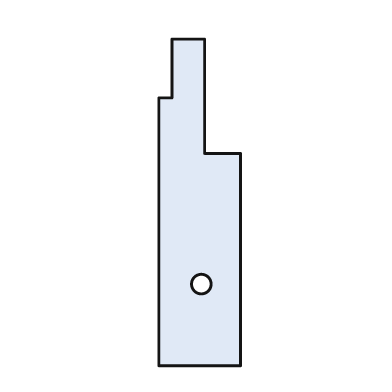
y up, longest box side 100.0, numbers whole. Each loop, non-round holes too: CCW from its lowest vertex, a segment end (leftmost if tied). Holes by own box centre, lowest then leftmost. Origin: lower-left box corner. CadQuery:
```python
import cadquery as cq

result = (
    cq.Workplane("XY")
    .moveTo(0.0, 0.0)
    .lineTo(25.0, 0.0)
    .lineTo(25.0, 65.0)
    .lineTo(14.0, 65.0)
    .lineTo(14.0, 100.0)
    .lineTo(4.0, 100.0)
    .lineTo(4.0, 82.0)
    .lineTo(0.0, 82.0)
    .close()
    .moveTo(13.0, 25.0)
    .circle(3.0)
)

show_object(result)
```